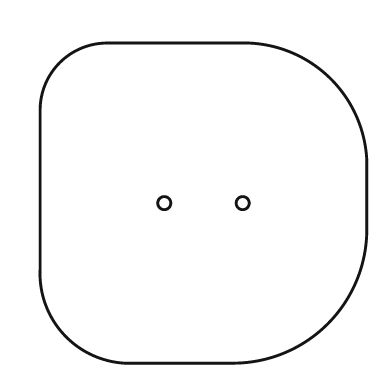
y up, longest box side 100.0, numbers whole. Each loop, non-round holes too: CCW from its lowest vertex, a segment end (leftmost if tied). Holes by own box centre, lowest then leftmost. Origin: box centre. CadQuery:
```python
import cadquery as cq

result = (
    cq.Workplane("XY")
    .moveTo(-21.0, -49.0)
    .lineTo(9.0, -49.0)
    .threePointArc((38.0, -37.0), (50.0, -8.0))
    .lineTo(50.0, 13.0)
    .threePointArc((39.0, 38.0), (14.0, 49.0))
    .lineTo(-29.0, 49.0)
    .threePointArc((-44.0, 43.0), (-50.0, 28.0))
    .lineTo(-50.0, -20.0)
    .threePointArc((-42.0, -41.0), (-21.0, -49.0))
    .close()
    .moveTo(-12.0, 0.0)
    .circle(2.0)
    .moveTo(12.0, 0.0)
    .circle(2.0)
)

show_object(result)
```